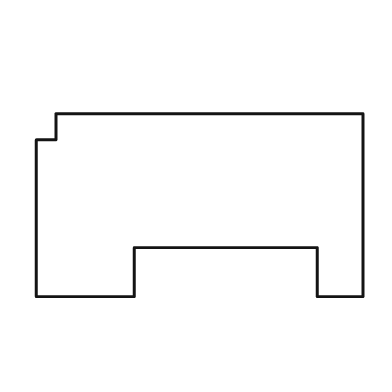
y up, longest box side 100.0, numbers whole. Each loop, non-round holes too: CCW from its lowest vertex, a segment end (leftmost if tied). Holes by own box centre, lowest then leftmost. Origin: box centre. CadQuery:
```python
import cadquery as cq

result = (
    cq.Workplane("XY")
    .moveTo(-50.0, -28.0)
    .lineTo(-20.0, -28.0)
    .lineTo(-20.0, -13.0)
    .lineTo(36.0, -13.0)
    .lineTo(36.0, -28.0)
    .lineTo(50.0, -28.0)
    .lineTo(50.0, 28.0)
    .lineTo(-44.0, 28.0)
    .lineTo(-44.0, 20.0)
    .lineTo(-50.0, 20.0)
    .close()
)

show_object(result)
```